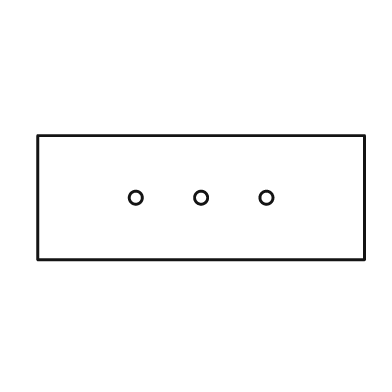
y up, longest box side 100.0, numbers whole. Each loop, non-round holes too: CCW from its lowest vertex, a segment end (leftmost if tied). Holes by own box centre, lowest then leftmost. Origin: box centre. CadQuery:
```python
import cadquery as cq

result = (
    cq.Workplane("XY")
    .moveTo(-50.0, -19.0)
    .lineTo(50.0, -19.0)
    .lineTo(50.0, 19.0)
    .lineTo(-50.0, 19.0)
    .close()
    .moveTo(-20.0, 0.0)
    .circle(2.0)
    .moveTo(0.0, 0.0)
    .circle(2.0)
    .moveTo(20.0, 0.0)
    .circle(2.0)
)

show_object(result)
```